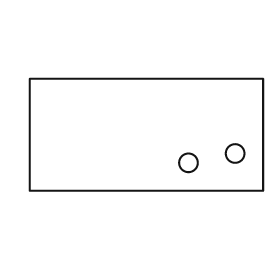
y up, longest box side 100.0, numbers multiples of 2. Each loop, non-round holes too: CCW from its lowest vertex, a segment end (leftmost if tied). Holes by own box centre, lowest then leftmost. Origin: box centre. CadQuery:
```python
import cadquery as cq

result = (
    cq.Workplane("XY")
    .moveTo(-50.0, -24.0)
    .lineTo(50.0, -24.0)
    .lineTo(50.0, 24.0)
    .lineTo(-50.0, 24.0)
    .close()
    .moveTo(18.0, -12.0)
    .circle(4.0)
    .moveTo(38.0, -8.0)
    .circle(4.0)
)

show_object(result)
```